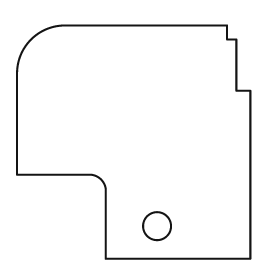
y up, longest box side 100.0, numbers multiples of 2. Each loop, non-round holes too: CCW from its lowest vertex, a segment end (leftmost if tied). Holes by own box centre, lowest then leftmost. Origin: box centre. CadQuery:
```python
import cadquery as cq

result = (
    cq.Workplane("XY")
    .moveTo(-12.0, -50.0)
    .lineTo(50.0, -50.0)
    .lineTo(50.0, 22.0)
    .lineTo(44.0, 22.0)
    .lineTo(44.0, 44.0)
    .lineTo(40.0, 44.0)
    .lineTo(40.0, 50.0)
    .lineTo(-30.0, 50.0)
    .threePointArc((-44.0, 44.0), (-50.0, 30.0))
    .lineTo(-50.0, -14.0)
    .lineTo(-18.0, -14.0)
    .threePointArc((-14.0, -16.0), (-12.0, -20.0))
    .close()
    .moveTo(10.0, -36.0)
    .circle(6.0)
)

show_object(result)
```